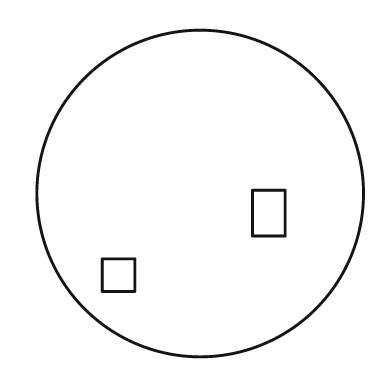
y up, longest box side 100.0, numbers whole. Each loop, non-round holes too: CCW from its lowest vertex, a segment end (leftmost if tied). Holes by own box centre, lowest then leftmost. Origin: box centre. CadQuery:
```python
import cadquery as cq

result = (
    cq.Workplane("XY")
    .moveTo(0.0, 0.0)
    .circle(50.0)
    .moveTo(-30.0, -30.0)
    .lineTo(-20.0, -30.0)
    .lineTo(-20.0, -20.0)
    .lineTo(-30.0, -20.0)
    .close()
    .moveTo(16.0, -13.0)
    .lineTo(26.0, -13.0)
    .lineTo(26.0, 1.0)
    .lineTo(16.0, 1.0)
    .close()
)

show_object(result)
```